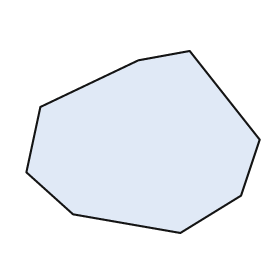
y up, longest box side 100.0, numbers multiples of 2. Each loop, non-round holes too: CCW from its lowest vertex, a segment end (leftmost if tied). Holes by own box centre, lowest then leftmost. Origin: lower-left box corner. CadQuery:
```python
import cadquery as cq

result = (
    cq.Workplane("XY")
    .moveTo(66.0, 0.0)
    .lineTo(92.0, 16.0)
    .lineTo(100.0, 40.0)
    .lineTo(70.0, 78.0)
    .lineTo(48.0, 74.0)
    .lineTo(6.0, 54.0)
    .lineTo(0.0, 26.0)
    .lineTo(20.0, 8.0)
    .close()
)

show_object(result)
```